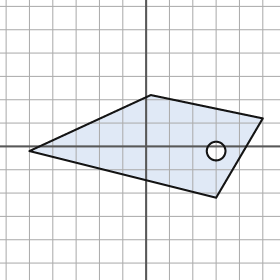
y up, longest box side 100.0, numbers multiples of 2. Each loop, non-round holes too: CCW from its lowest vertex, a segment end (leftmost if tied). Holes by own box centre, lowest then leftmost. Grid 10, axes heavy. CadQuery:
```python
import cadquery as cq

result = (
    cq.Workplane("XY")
    .moveTo(30.0, -22.0)
    .lineTo(50.0, 12.0)
    .lineTo(2.0, 22.0)
    .lineTo(-50.0, -2.0)
    .close()
    .moveTo(30.0, -2.0)
    .circle(4.0)
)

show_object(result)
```